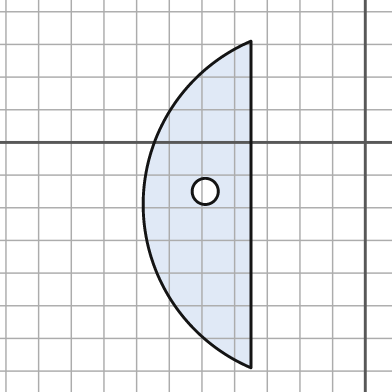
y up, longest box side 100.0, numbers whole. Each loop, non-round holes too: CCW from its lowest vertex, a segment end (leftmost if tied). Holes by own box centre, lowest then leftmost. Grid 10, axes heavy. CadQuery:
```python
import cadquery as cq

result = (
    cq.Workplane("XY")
    .moveTo(-35.0, -69.0)
    .lineTo(-35.0, 31.0)
    .threePointArc((-68.0, -19.0), (-35.0, -69.0))
    .close()
    .moveTo(-49.0, -15.0)
    .circle(4.0)
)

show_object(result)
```